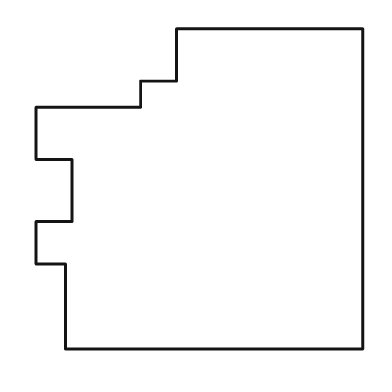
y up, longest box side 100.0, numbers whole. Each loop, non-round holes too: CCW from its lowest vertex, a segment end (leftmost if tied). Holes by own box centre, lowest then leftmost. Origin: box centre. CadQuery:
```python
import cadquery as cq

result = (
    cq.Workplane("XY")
    .moveTo(-41.0, -49.0)
    .lineTo(50.0, -49.0)
    .lineTo(50.0, 49.0)
    .lineTo(-7.0, 49.0)
    .lineTo(-7.0, 33.0)
    .lineTo(-18.0, 33.0)
    .lineTo(-18.0, 25.0)
    .lineTo(-50.0, 25.0)
    .lineTo(-50.0, 9.0)
    .lineTo(-39.0, 9.0)
    .lineTo(-39.0, -10.0)
    .lineTo(-50.0, -10.0)
    .lineTo(-50.0, -23.0)
    .lineTo(-41.0, -23.0)
    .close()
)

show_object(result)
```